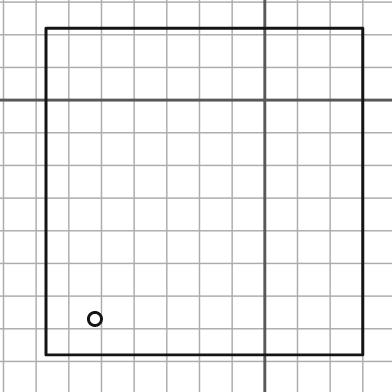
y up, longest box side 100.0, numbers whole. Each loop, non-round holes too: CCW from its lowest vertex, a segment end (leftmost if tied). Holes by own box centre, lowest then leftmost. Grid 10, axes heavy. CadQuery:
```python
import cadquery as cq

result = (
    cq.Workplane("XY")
    .moveTo(-67.0, -78.0)
    .lineTo(30.0, -78.0)
    .lineTo(30.0, 22.0)
    .lineTo(-67.0, 22.0)
    .close()
    .moveTo(-52.0, -67.0)
    .circle(2.0)
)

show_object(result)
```